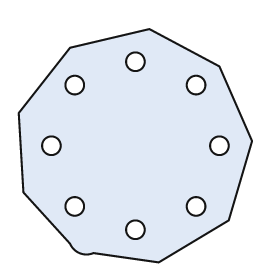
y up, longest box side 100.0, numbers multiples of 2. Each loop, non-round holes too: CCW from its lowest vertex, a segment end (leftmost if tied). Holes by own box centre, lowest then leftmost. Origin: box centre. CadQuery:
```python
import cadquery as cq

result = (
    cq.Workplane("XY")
    .moveTo(10.0, -50.0)
    .lineTo(40.0, -32.0)
    .lineTo(50.0, 2.0)
    .lineTo(36.0, 34.0)
    .lineTo(6.0, 50.0)
    .lineTo(-28.0, 42.0)
    .lineTo(-50.0, 14.0)
    .lineTo(-48.0, -20.0)
    .lineTo(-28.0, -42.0)
    .threePointArc((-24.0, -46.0), (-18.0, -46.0))
    .close()
    .moveTo(0.0, -36.0)
    .circle(4.0)
    .moveTo(-26.0, -26.0)
    .circle(4.0)
    .moveTo(26.0, -26.0)
    .circle(4.0)
    .moveTo(-36.0, 0.0)
    .circle(4.0)
    .moveTo(36.0, 0.0)
    .circle(4.0)
    .moveTo(-26.0, 26.0)
    .circle(4.0)
    .moveTo(26.0, 26.0)
    .circle(4.0)
    .moveTo(0.0, 36.0)
    .circle(4.0)
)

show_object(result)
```